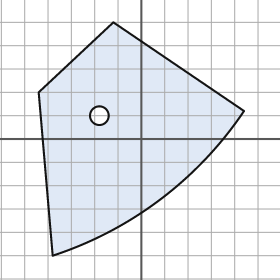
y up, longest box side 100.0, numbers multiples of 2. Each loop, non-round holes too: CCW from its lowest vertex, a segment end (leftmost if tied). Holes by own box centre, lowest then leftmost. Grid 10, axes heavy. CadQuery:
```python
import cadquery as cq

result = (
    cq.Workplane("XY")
    .moveTo(-38.0, -50.0)
    .threePointArc((8.0, -26.0), (44.0, 12.0))
    .lineTo(-12.0, 50.0)
    .lineTo(-44.0, 20.0)
    .close()
    .moveTo(-18.0, 10.0)
    .circle(4.0)
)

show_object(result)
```